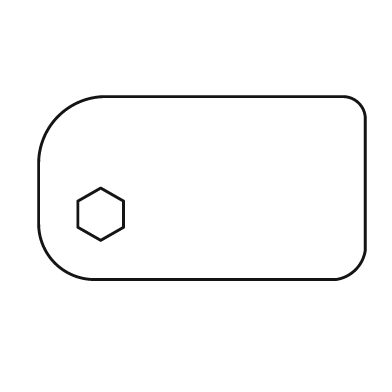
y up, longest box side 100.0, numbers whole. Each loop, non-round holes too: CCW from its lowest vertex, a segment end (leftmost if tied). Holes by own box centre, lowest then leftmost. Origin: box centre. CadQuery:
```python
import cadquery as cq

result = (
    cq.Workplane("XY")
    .moveTo(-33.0, -28.0)
    .lineTo(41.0, -28.0)
    .threePointArc((47.0, -25.0), (50.0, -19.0))
    .lineTo(50.0, 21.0)
    .threePointArc((48.0, 26.0), (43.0, 28.0))
    .lineTo(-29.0, 28.0)
    .threePointArc((-44.0, 22.0), (-50.0, 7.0))
    .lineTo(-50.0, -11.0)
    .threePointArc((-45.0, -23.0), (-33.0, -28.0))
    .close()
    .moveTo(-31.0, -16.0)
    .lineTo(-24.0, -12.0)
    .lineTo(-24.0, -4.0)
    .lineTo(-31.0, 0.0)
    .lineTo(-38.0, -4.0)
    .lineTo(-38.0, -12.0)
    .close()
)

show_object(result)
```